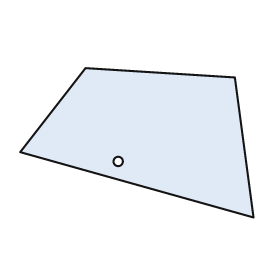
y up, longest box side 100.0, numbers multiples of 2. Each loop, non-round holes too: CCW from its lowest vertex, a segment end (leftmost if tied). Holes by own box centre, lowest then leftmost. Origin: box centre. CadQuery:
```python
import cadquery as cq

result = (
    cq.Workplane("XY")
    .moveTo(50.0, -32.0)
    .lineTo(42.0, 28.0)
    .lineTo(-22.0, 32.0)
    .lineTo(-50.0, -4.0)
    .close()
    .moveTo(-8.0, -8.0)
    .circle(2.0)
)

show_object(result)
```